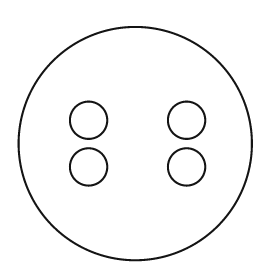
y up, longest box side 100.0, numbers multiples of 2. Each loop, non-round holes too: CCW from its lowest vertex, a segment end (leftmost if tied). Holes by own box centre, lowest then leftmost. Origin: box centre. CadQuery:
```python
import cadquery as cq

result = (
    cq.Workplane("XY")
    .moveTo(0.0, 0.0)
    .circle(50.0)
    .moveTo(-20.0, -10.0)
    .circle(8.0)
    .moveTo(22.0, -10.0)
    .circle(8.0)
    .moveTo(-20.0, 10.0)
    .circle(8.0)
    .moveTo(22.0, 10.0)
    .circle(8.0)
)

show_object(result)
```